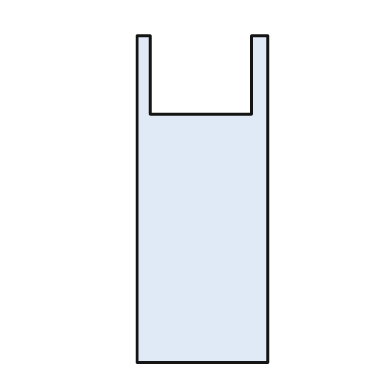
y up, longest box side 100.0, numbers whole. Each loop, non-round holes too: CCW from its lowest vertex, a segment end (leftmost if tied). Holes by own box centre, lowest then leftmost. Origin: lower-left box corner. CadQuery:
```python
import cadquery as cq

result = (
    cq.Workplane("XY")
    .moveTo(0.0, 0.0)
    .lineTo(40.0, 0.0)
    .lineTo(40.0, 100.0)
    .lineTo(35.0, 100.0)
    .lineTo(35.0, 76.0)
    .lineTo(4.0, 76.0)
    .lineTo(4.0, 100.0)
    .lineTo(0.0, 100.0)
    .close()
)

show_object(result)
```